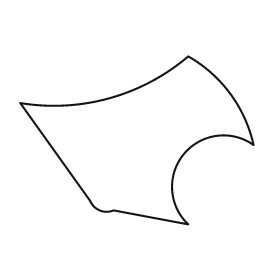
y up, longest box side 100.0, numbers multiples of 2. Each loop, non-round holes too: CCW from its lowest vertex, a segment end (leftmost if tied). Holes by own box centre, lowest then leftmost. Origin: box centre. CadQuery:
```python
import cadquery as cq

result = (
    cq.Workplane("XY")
    .moveTo(22.0, -36.0)
    .threePointArc((20.0, -6.0), (50.0, -2.0))
    .threePointArc((40.0, 20.0), (22.0, 36.0))
    .threePointArc((-12.0, 18.0), (-50.0, 16.0))
    .lineTo(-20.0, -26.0)
    .threePointArc((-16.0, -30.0), (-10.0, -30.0))
    .close()
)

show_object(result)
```